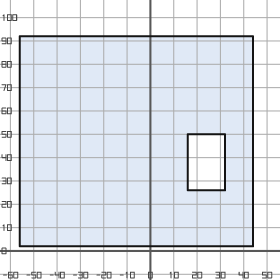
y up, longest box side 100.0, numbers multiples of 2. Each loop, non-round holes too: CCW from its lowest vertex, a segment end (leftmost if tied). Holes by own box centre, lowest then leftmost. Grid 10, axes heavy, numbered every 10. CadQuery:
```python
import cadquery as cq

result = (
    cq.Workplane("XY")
    .moveTo(-56.0, 2.0)
    .lineTo(44.0, 2.0)
    .lineTo(44.0, 92.0)
    .lineTo(-56.0, 92.0)
    .close()
    .moveTo(16.0, 26.0)
    .lineTo(32.0, 26.0)
    .lineTo(32.0, 50.0)
    .lineTo(16.0, 50.0)
    .close()
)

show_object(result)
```